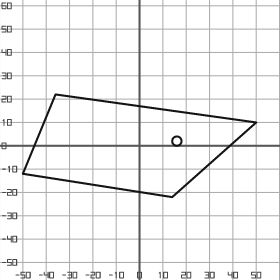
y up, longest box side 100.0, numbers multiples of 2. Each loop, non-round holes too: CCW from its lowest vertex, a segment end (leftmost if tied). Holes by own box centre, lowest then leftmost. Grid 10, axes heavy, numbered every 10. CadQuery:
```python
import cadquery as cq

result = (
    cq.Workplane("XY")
    .moveTo(14.0, -22.0)
    .lineTo(50.0, 10.0)
    .lineTo(-36.0, 22.0)
    .lineTo(-50.0, -12.0)
    .close()
    .moveTo(16.0, 2.0)
    .circle(2.0)
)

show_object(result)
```